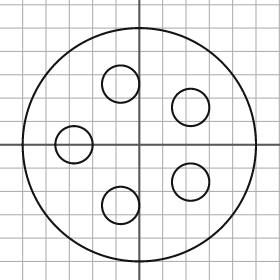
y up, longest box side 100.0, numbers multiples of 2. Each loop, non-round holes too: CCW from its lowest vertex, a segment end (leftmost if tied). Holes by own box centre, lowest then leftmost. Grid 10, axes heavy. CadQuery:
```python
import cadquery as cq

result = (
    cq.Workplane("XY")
    .moveTo(0.0, 0.0)
    .circle(50.0)
    .moveTo(-8.0, -26.0)
    .circle(8.0)
    .moveTo(22.0, -16.0)
    .circle(8.0)
    .moveTo(-28.0, 0.0)
    .circle(8.0)
    .moveTo(22.0, 16.0)
    .circle(8.0)
    .moveTo(-8.0, 26.0)
    .circle(8.0)
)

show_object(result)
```